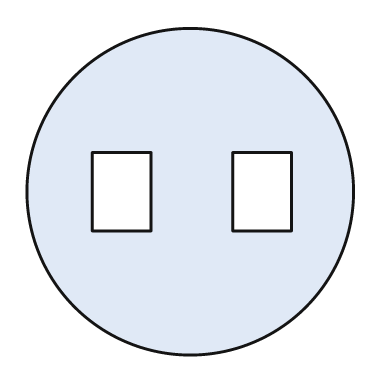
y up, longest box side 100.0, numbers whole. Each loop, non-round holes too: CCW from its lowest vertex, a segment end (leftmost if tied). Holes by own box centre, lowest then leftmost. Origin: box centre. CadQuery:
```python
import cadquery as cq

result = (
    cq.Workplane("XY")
    .moveTo(0.0, 0.0)
    .circle(50.0)
    .moveTo(-30.0, -12.0)
    .lineTo(-12.0, -12.0)
    .lineTo(-12.0, 12.0)
    .lineTo(-30.0, 12.0)
    .close()
    .moveTo(13.0, -12.0)
    .lineTo(31.0, -12.0)
    .lineTo(31.0, 12.0)
    .lineTo(13.0, 12.0)
    .close()
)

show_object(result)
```